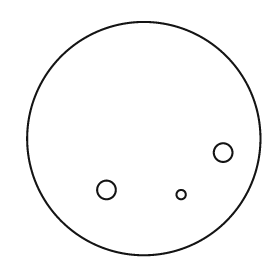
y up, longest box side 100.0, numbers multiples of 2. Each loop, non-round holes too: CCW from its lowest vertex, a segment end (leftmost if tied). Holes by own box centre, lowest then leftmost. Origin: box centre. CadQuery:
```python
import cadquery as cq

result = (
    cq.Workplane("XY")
    .moveTo(0.0, 0.0)
    .circle(50.0)
    .moveTo(16.0, -24.0)
    .circle(2.0)
    .moveTo(-16.0, -22.0)
    .circle(4.0)
    .moveTo(34.0, -6.0)
    .circle(4.0)
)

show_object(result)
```